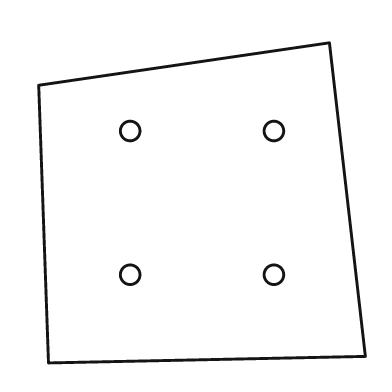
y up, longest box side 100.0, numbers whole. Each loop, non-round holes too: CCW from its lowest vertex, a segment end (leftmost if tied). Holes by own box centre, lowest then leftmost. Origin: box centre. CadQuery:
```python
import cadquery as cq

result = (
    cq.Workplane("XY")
    .moveTo(-47.0, -49.0)
    .lineTo(50.0, -47.0)
    .lineTo(39.0, 49.0)
    .lineTo(-50.0, 36.0)
    .close()
    .moveTo(-22.0, -22.0)
    .circle(3.0)
    .moveTo(22.0, -22.0)
    .circle(3.0)
    .moveTo(-22.0, 22.0)
    .circle(3.0)
    .moveTo(22.0, 22.0)
    .circle(3.0)
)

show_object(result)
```